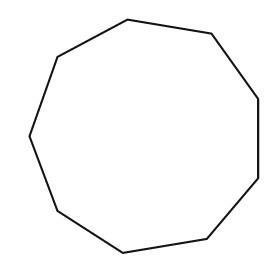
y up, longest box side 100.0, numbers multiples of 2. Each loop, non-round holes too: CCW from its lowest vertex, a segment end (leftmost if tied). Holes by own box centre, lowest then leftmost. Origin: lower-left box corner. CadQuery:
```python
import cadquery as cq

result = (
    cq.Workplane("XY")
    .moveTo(40.0, 0.0)
    .lineTo(76.0, 6.0)
    .lineTo(98.0, 32.0)
    .lineTo(98.0, 66.0)
    .lineTo(78.0, 94.0)
    .lineTo(42.0, 100.0)
    .lineTo(12.0, 84.0)
    .lineTo(0.0, 50.0)
    .lineTo(12.0, 18.0)
    .close()
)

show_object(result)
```